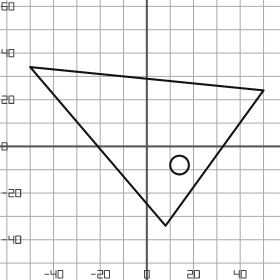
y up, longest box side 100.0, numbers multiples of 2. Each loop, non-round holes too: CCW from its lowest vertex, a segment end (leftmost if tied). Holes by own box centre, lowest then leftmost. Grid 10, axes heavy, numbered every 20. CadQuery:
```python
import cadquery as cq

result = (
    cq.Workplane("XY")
    .moveTo(8.0, -34.0)
    .lineTo(50.0, 24.0)
    .lineTo(-50.0, 34.0)
    .close()
    .moveTo(14.0, -8.0)
    .circle(4.0)
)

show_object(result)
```